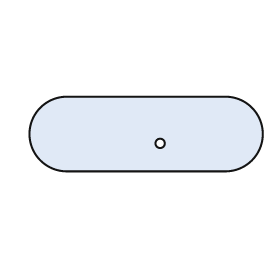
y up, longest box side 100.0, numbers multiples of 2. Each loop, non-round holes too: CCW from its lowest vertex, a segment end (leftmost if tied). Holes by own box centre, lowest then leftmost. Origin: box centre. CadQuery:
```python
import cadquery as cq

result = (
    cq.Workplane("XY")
    .moveTo(-34.0, -16.0)
    .lineTo(34.0, -16.0)
    .threePointArc((50.0, 0.0), (34.0, 16.0))
    .lineTo(-34.0, 16.0)
    .threePointArc((-50.0, 0.0), (-34.0, -16.0))
    .close()
    .moveTo(6.0, -4.0)
    .circle(2.0)
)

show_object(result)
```